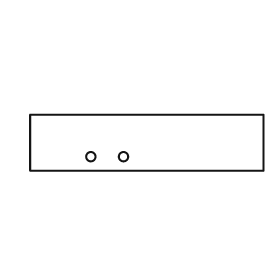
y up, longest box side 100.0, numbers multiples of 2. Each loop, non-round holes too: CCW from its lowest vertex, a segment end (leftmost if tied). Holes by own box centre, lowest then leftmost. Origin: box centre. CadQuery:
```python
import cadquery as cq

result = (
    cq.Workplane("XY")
    .moveTo(-50.0, -12.0)
    .lineTo(50.0, -12.0)
    .lineTo(50.0, 12.0)
    .lineTo(-50.0, 12.0)
    .close()
    .moveTo(-24.0, -6.0)
    .circle(2.0)
    .moveTo(-10.0, -6.0)
    .circle(2.0)
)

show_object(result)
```